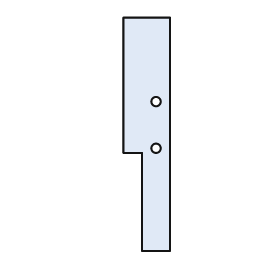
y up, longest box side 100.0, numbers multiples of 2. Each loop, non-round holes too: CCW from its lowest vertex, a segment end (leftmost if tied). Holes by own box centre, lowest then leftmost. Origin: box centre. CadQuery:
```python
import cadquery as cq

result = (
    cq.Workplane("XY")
    .moveTo(-2.0, -50.0)
    .lineTo(10.0, -50.0)
    .lineTo(10.0, 50.0)
    .lineTo(-10.0, 50.0)
    .lineTo(-10.0, -8.0)
    .lineTo(-2.0, -8.0)
    .close()
    .moveTo(4.0, -6.0)
    .circle(2.0)
    .moveTo(4.0, 14.0)
    .circle(2.0)
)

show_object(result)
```